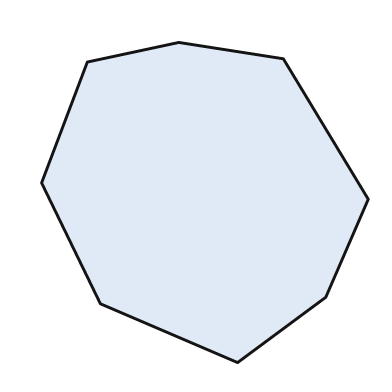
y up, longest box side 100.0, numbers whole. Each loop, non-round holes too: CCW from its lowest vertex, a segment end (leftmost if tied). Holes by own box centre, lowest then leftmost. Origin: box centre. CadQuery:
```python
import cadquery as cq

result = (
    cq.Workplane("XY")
    .moveTo(10.0, -49.0)
    .lineTo(37.0, -29.0)
    .lineTo(50.0, 1.0)
    .lineTo(24.0, 44.0)
    .lineTo(-8.0, 49.0)
    .lineTo(-36.0, 43.0)
    .lineTo(-50.0, 6.0)
    .lineTo(-32.0, -31.0)
    .close()
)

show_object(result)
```